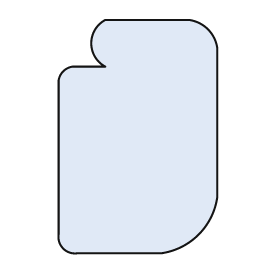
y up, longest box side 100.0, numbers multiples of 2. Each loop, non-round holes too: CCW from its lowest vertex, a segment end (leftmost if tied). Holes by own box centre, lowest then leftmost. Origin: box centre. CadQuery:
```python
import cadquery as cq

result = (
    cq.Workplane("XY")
    .moveTo(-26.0, -50.0)
    .lineTo(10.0, -50.0)
    .threePointArc((26.0, -42.0), (34.0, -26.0))
    .lineTo(34.0, 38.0)
    .threePointArc((30.0, 46.0), (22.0, 50.0))
    .lineTo(-14.0, 50.0)
    .threePointArc((-20.0, 40.0), (-14.0, 30.0))
    .lineTo(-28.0, 30.0)
    .threePointArc((-32.0, 28.0), (-34.0, 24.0))
    .lineTo(-34.0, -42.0)
    .threePointArc((-32.0, -48.0), (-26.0, -50.0))
    .close()
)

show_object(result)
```